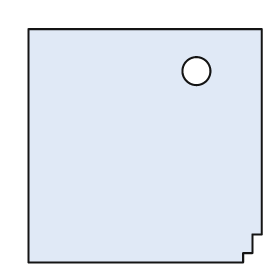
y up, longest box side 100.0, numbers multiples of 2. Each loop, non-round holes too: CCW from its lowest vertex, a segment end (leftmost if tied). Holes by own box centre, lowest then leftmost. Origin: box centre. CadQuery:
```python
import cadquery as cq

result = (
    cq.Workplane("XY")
    .moveTo(-50.0, -50.0)
    .lineTo(42.0, -50.0)
    .lineTo(42.0, -46.0)
    .lineTo(46.0, -46.0)
    .lineTo(46.0, -38.0)
    .lineTo(50.0, -38.0)
    .lineTo(50.0, 50.0)
    .lineTo(-50.0, 50.0)
    .close()
    .moveTo(22.0, 32.0)
    .circle(6.0)
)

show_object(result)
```